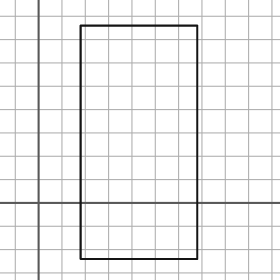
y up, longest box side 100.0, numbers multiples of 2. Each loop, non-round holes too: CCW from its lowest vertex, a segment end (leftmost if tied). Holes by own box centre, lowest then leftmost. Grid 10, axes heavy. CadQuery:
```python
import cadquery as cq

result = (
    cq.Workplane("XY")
    .moveTo(18.0, -24.0)
    .lineTo(68.0, -24.0)
    .lineTo(68.0, 76.0)
    .lineTo(18.0, 76.0)
    .close()
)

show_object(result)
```